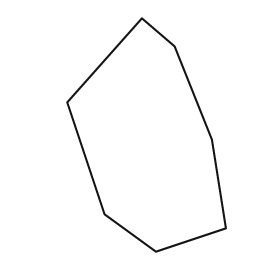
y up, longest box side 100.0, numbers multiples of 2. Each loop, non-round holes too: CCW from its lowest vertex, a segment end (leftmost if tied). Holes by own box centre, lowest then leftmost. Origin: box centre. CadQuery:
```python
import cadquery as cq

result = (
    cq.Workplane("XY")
    .moveTo(4.0, -50.0)
    .lineTo(34.0, -40.0)
    .lineTo(28.0, -2.0)
    .lineTo(12.0, 38.0)
    .lineTo(-2.0, 50.0)
    .lineTo(-34.0, 14.0)
    .lineTo(-18.0, -34.0)
    .close()
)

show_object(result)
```